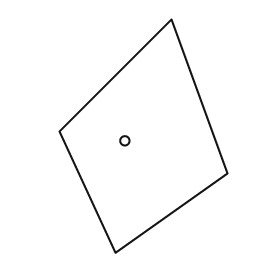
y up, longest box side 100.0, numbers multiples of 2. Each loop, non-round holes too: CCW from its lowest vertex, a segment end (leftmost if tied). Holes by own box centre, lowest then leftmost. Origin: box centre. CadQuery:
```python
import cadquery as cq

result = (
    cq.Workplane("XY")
    .moveTo(-12.0, -50.0)
    .lineTo(36.0, -16.0)
    .lineTo(12.0, 50.0)
    .lineTo(-36.0, 2.0)
    .close()
    .moveTo(-8.0, -2.0)
    .circle(2.0)
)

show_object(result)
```